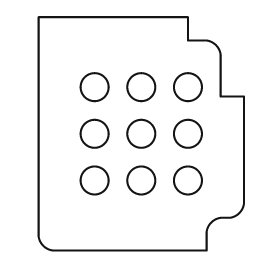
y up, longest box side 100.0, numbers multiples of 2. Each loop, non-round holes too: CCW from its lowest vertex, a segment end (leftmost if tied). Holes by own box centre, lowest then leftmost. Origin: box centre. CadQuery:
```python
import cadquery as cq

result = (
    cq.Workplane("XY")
    .moveTo(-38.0, -50.0)
    .lineTo(28.0, -50.0)
    .lineTo(28.0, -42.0)
    .threePointArc((30.0, -38.0), (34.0, -36.0))
    .lineTo(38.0, -36.0)
    .threePointArc((42.0, -34.0), (44.0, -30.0))
    .lineTo(44.0, 16.0)
    .lineTo(34.0, 16.0)
    .lineTo(34.0, 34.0)
    .threePointArc((32.0, 38.0), (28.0, 40.0))
    .lineTo(20.0, 40.0)
    .lineTo(20.0, 50.0)
    .lineTo(-44.0, 50.0)
    .lineTo(-44.0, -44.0)
    .threePointArc((-42.0, -48.0), (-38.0, -50.0))
    .close()
    .moveTo(-20.0, -20.0)
    .circle(6.0)
    .moveTo(0.0, -20.0)
    .circle(6.0)
    .moveTo(20.0, -20.0)
    .circle(6.0)
    .moveTo(-20.0, 0.0)
    .circle(6.0)
    .moveTo(0.0, 0.0)
    .circle(6.0)
    .moveTo(20.0, 0.0)
    .circle(6.0)
    .moveTo(-20.0, 20.0)
    .circle(6.0)
    .moveTo(0.0, 20.0)
    .circle(6.0)
    .moveTo(20.0, 20.0)
    .circle(6.0)
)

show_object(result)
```